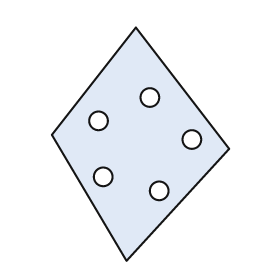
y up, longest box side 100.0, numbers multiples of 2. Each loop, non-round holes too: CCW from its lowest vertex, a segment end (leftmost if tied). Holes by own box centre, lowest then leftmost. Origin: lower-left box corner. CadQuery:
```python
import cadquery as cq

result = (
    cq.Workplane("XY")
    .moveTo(32.0, 0.0)
    .lineTo(76.0, 48.0)
    .lineTo(36.0, 100.0)
    .lineTo(0.0, 54.0)
    .close()
    .moveTo(46.0, 30.0)
    .circle(4.0)
    .moveTo(22.0, 36.0)
    .circle(4.0)
    .moveTo(60.0, 52.0)
    .circle(4.0)
    .moveTo(20.0, 60.0)
    .circle(4.0)
    .moveTo(42.0, 70.0)
    .circle(4.0)
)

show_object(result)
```